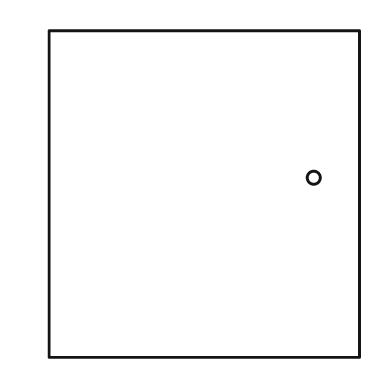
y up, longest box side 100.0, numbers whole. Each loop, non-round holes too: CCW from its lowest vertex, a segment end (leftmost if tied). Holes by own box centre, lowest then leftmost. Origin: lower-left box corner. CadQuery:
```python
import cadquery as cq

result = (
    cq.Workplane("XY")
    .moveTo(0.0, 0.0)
    .lineTo(95.0, 0.0)
    .lineTo(95.0, 100.0)
    .lineTo(0.0, 100.0)
    .close()
    .moveTo(81.0, 55.0)
    .circle(2.0)
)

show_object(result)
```